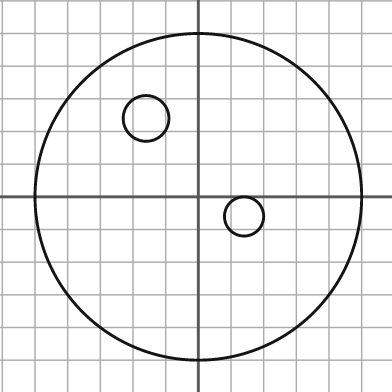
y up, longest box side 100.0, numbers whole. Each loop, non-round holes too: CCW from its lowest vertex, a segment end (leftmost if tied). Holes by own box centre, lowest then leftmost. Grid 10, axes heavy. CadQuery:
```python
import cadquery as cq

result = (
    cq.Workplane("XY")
    .moveTo(0.0, 0.0)
    .circle(50.0)
    .moveTo(14.0, -6.0)
    .circle(6.0)
    .moveTo(-16.0, 24.0)
    .circle(7.0)
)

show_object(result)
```